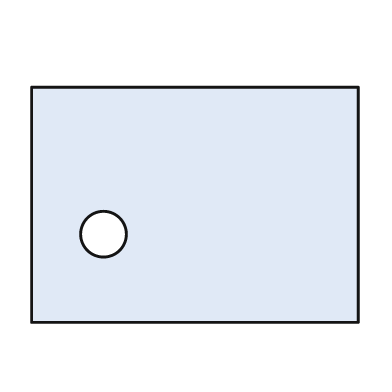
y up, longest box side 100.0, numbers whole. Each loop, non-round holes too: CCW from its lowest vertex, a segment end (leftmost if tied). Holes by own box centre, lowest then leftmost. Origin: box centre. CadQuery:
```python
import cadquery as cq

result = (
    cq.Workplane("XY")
    .moveTo(-50.0, -36.0)
    .lineTo(50.0, -36.0)
    .lineTo(50.0, 36.0)
    .lineTo(-50.0, 36.0)
    .close()
    .moveTo(-28.0, -9.0)
    .circle(7.0)
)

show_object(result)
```